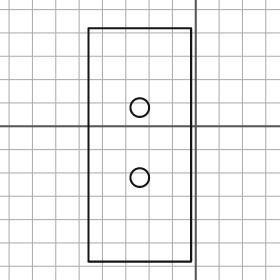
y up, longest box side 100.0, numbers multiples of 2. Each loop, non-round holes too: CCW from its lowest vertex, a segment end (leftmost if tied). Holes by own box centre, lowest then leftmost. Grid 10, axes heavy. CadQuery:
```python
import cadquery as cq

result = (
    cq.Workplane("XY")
    .moveTo(-46.0, -58.0)
    .lineTo(-2.0, -58.0)
    .lineTo(-2.0, 42.0)
    .lineTo(-46.0, 42.0)
    .close()
    .moveTo(-24.0, -22.0)
    .circle(4.0)
    .moveTo(-24.0, 8.0)
    .circle(4.0)
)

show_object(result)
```